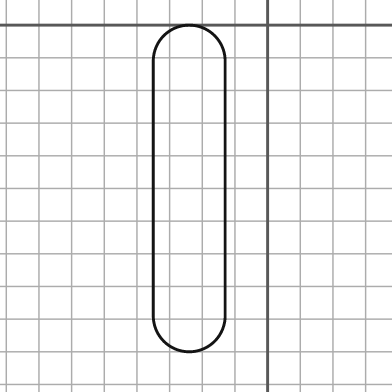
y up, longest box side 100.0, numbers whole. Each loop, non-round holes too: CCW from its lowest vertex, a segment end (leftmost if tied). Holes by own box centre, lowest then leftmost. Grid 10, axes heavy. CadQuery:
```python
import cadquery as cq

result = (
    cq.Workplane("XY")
    .moveTo(-35.0, -89.0)
    .threePointArc((-24.0, -100.0), (-13.0, -89.0))
    .lineTo(-13.0, -11.0)
    .threePointArc((-24.0, 0.0), (-35.0, -11.0))
    .close()
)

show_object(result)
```